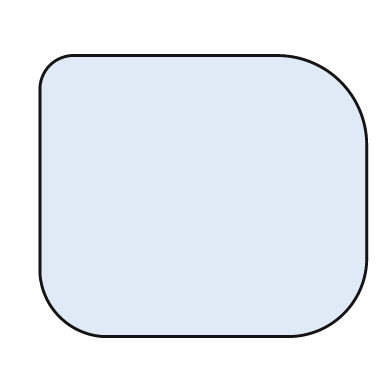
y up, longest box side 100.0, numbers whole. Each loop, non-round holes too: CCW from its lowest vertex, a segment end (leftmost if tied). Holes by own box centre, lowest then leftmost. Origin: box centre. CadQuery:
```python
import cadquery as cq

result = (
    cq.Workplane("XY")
    .moveTo(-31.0, -43.0)
    .lineTo(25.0, -43.0)
    .threePointArc((43.0, -36.0), (50.0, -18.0))
    .lineTo(50.0, 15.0)
    .threePointArc((42.0, 35.0), (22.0, 43.0))
    .lineTo(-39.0, 43.0)
    .threePointArc((-47.0, 40.0), (-50.0, 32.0))
    .lineTo(-50.0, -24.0)
    .threePointArc((-44.0, -37.0), (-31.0, -43.0))
    .close()
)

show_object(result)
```